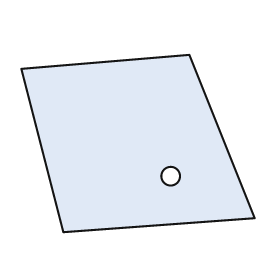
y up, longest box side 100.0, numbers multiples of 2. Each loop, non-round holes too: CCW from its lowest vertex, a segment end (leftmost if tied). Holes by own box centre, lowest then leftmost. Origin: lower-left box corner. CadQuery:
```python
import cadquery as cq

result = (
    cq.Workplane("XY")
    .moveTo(18.0, 0.0)
    .lineTo(100.0, 6.0)
    .lineTo(72.0, 76.0)
    .lineTo(0.0, 70.0)
    .close()
    .moveTo(64.0, 24.0)
    .circle(4.0)
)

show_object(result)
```